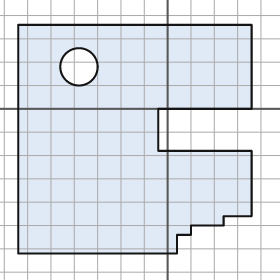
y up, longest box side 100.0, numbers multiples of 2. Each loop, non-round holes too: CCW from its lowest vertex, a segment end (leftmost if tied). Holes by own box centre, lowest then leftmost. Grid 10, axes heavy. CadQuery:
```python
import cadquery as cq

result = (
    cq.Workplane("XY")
    .moveTo(-64.0, -62.0)
    .lineTo(4.0, -62.0)
    .lineTo(4.0, -54.0)
    .lineTo(10.0, -54.0)
    .lineTo(10.0, -50.0)
    .lineTo(24.0, -50.0)
    .lineTo(24.0, -46.0)
    .lineTo(36.0, -46.0)
    .lineTo(36.0, -18.0)
    .lineTo(-4.0, -18.0)
    .lineTo(-4.0, 0.0)
    .lineTo(36.0, 0.0)
    .lineTo(36.0, 36.0)
    .lineTo(-64.0, 36.0)
    .close()
    .moveTo(-38.0, 18.0)
    .circle(8.0)
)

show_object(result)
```